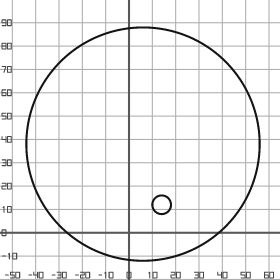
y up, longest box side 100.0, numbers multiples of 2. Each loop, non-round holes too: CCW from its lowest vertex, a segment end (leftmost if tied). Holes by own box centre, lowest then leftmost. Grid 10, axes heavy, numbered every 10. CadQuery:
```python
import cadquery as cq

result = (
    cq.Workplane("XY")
    .moveTo(6.0, 38.0)
    .circle(50.0)
    .moveTo(14.0, 12.0)
    .circle(4.0)
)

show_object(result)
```